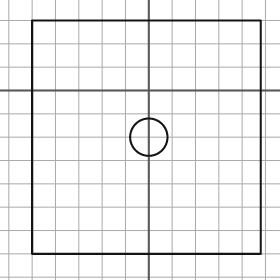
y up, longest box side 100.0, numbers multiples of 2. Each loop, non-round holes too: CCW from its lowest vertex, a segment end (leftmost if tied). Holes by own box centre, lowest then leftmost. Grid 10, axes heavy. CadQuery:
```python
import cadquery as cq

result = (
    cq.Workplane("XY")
    .moveTo(-50.0, -70.0)
    .lineTo(48.0, -70.0)
    .lineTo(48.0, 30.0)
    .lineTo(-50.0, 30.0)
    .close()
    .moveTo(0.0, -20.0)
    .circle(8.0)
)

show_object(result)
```